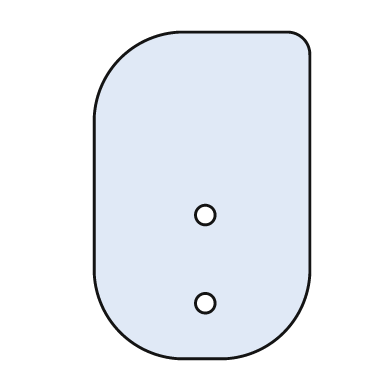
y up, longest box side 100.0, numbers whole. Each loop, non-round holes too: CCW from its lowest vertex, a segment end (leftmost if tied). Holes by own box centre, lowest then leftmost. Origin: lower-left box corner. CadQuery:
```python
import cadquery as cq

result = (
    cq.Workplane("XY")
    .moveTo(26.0, 0.0)
    .lineTo(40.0, 0.0)
    .threePointArc((58.0, 8.0), (66.0, 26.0))
    .lineTo(66.0, 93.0)
    .threePointArc((64.0, 98.0), (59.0, 100.0))
    .lineTo(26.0, 100.0)
    .threePointArc((8.0, 92.0), (0.0, 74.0))
    .lineTo(0.0, 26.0)
    .threePointArc((8.0, 8.0), (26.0, 0.0))
    .close()
    .moveTo(34.0, 17.0)
    .circle(3.0)
    .moveTo(34.0, 44.0)
    .circle(3.0)
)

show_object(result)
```